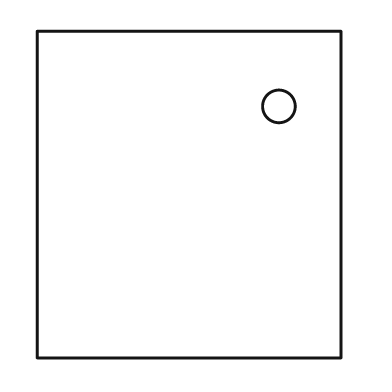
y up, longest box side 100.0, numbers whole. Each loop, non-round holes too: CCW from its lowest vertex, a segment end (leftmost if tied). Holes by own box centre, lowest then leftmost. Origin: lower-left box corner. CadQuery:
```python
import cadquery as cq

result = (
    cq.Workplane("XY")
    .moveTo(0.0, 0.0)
    .lineTo(93.0, 0.0)
    .lineTo(93.0, 100.0)
    .lineTo(0.0, 100.0)
    .close()
    .moveTo(74.0, 77.0)
    .circle(5.0)
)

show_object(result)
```